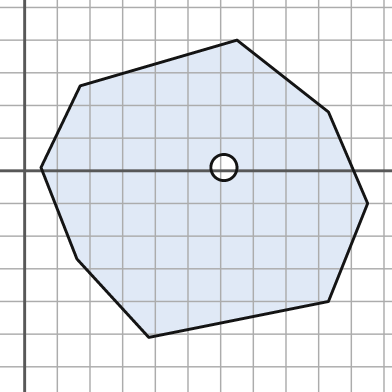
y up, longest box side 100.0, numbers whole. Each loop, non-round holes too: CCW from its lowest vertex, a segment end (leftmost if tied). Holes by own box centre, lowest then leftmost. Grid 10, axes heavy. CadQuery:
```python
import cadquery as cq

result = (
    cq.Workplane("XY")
    .moveTo(38.0, -51.0)
    .lineTo(93.0, -40.0)
    .lineTo(105.0, -10.0)
    .lineTo(93.0, 18.0)
    .lineTo(65.0, 40.0)
    .lineTo(17.0, 26.0)
    .lineTo(5.0, 1.0)
    .lineTo(16.0, -27.0)
    .close()
    .moveTo(61.0, 1.0)
    .circle(4.0)
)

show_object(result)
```